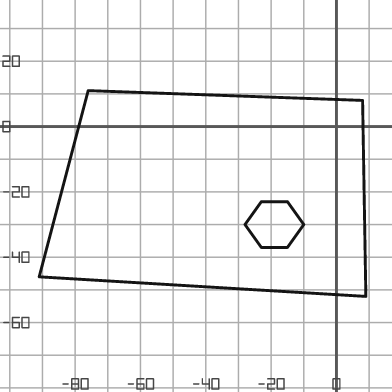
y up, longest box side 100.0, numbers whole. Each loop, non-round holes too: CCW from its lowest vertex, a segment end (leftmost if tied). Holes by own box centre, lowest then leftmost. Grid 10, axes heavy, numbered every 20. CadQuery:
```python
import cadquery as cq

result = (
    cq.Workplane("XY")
    .moveTo(9.0, -52.0)
    .lineTo(8.0, 8.0)
    .lineTo(-76.0, 11.0)
    .lineTo(-91.0, -46.0)
    .close()
    .moveTo(-23.0, -37.0)
    .lineTo(-15.0, -37.0)
    .lineTo(-10.0, -30.0)
    .lineTo(-15.0, -23.0)
    .lineTo(-23.0, -23.0)
    .lineTo(-28.0, -30.0)
    .close()
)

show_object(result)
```